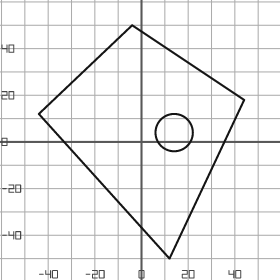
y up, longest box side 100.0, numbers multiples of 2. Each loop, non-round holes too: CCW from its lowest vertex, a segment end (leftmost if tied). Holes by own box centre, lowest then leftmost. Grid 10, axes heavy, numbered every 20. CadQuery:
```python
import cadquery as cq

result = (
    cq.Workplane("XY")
    .moveTo(12.0, -50.0)
    .lineTo(44.0, 18.0)
    .lineTo(-4.0, 50.0)
    .lineTo(-44.0, 12.0)
    .close()
    .moveTo(14.0, 4.0)
    .circle(8.0)
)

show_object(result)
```